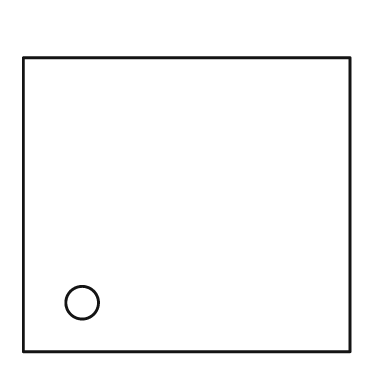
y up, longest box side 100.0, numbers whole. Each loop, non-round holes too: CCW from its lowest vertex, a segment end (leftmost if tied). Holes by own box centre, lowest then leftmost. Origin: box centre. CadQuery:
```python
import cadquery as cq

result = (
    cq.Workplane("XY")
    .moveTo(-50.0, -45.0)
    .lineTo(50.0, -45.0)
    .lineTo(50.0, 45.0)
    .lineTo(-50.0, 45.0)
    .close()
    .moveTo(-32.0, -30.0)
    .circle(5.0)
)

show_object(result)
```